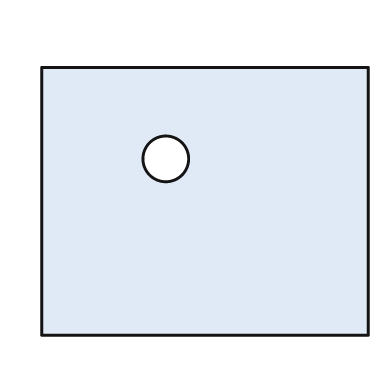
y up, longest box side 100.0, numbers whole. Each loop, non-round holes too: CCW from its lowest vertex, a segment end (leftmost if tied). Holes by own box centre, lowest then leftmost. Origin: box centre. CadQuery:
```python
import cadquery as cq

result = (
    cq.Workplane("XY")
    .moveTo(-50.0, -41.0)
    .lineTo(50.0, -41.0)
    .lineTo(50.0, 41.0)
    .lineTo(-50.0, 41.0)
    .close()
    .moveTo(-12.0, 13.0)
    .circle(7.0)
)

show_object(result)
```